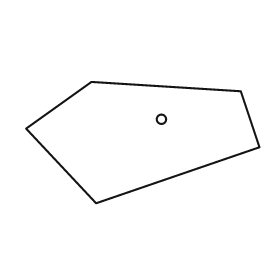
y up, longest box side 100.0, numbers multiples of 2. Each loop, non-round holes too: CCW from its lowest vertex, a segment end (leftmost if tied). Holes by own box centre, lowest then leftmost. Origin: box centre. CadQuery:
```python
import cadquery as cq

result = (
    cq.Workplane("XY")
    .moveTo(-20.0, -26.0)
    .lineTo(50.0, -2.0)
    .lineTo(42.0, 22.0)
    .lineTo(-22.0, 26.0)
    .lineTo(-50.0, 6.0)
    .close()
    .moveTo(8.0, 10.0)
    .circle(2.0)
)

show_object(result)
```